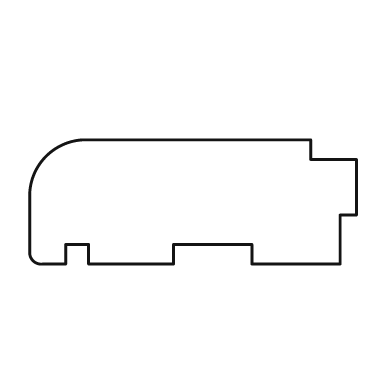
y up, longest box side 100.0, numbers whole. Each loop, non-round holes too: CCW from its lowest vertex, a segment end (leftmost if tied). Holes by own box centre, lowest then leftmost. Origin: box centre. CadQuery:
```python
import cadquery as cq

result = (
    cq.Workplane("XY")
    .moveTo(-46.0, -19.0)
    .lineTo(-39.0, -19.0)
    .lineTo(-39.0, -13.0)
    .lineTo(-32.0, -13.0)
    .lineTo(-32.0, -19.0)
    .lineTo(-6.0, -19.0)
    .lineTo(-6.0, -13.0)
    .lineTo(18.0, -13.0)
    .lineTo(18.0, -19.0)
    .lineTo(45.0, -19.0)
    .lineTo(45.0, -4.0)
    .lineTo(50.0, -4.0)
    .lineTo(50.0, 13.0)
    .lineTo(36.0, 13.0)
    .lineTo(36.0, 19.0)
    .lineTo(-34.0, 19.0)
    .threePointArc((-45.0, 14.0), (-50.0, 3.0))
    .lineTo(-50.0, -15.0)
    .threePointArc((-49.0, -18.0), (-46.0, -19.0))
    .close()
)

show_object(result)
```